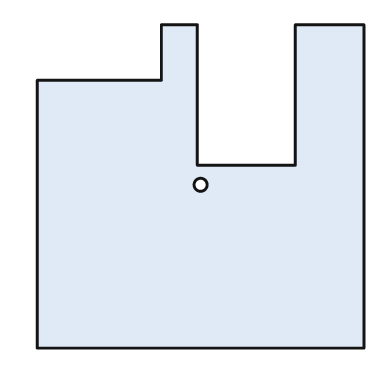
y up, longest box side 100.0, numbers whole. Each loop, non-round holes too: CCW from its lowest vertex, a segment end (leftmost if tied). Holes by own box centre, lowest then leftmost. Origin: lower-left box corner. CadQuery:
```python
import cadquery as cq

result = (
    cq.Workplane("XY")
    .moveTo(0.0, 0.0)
    .lineTo(100.0, 0.0)
    .lineTo(100.0, 99.0)
    .lineTo(79.0, 99.0)
    .lineTo(79.0, 56.0)
    .lineTo(49.0, 56.0)
    .lineTo(49.0, 99.0)
    .lineTo(38.0, 99.0)
    .lineTo(38.0, 82.0)
    .lineTo(0.0, 82.0)
    .close()
    .moveTo(50.0, 50.0)
    .circle(2.0)
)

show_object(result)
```